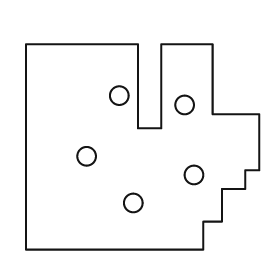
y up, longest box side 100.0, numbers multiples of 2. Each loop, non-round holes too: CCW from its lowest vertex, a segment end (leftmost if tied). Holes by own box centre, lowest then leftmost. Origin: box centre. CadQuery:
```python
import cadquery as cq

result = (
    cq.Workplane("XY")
    .moveTo(-50.0, -44.0)
    .lineTo(26.0, -44.0)
    .lineTo(26.0, -32.0)
    .lineTo(34.0, -32.0)
    .lineTo(34.0, -18.0)
    .lineTo(44.0, -18.0)
    .lineTo(44.0, -10.0)
    .lineTo(50.0, -10.0)
    .lineTo(50.0, 14.0)
    .lineTo(30.0, 14.0)
    .lineTo(30.0, 44.0)
    .lineTo(8.0, 44.0)
    .lineTo(8.0, 8.0)
    .lineTo(-2.0, 8.0)
    .lineTo(-2.0, 44.0)
    .lineTo(-50.0, 44.0)
    .close()
    .moveTo(-4.0, -24.0)
    .circle(4.0)
    .moveTo(22.0, -12.0)
    .circle(4.0)
    .moveTo(-24.0, -4.0)
    .circle(4.0)
    .moveTo(18.0, 18.0)
    .circle(4.0)
    .moveTo(-10.0, 22.0)
    .circle(4.0)
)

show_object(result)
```